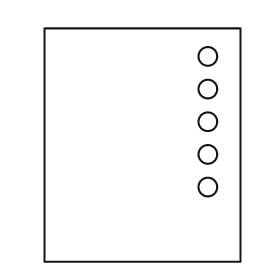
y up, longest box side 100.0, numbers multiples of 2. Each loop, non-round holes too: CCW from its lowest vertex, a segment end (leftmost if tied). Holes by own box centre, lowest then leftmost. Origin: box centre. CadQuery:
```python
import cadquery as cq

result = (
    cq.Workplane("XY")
    .moveTo(-42.0, -50.0)
    .lineTo(42.0, -50.0)
    .lineTo(42.0, 50.0)
    .lineTo(-42.0, 50.0)
    .close()
    .moveTo(28.0, -18.0)
    .circle(4.0)
    .moveTo(28.0, -4.0)
    .circle(4.0)
    .moveTo(28.0, 10.0)
    .circle(4.0)
    .moveTo(28.0, 24.0)
    .circle(4.0)
    .moveTo(28.0, 38.0)
    .circle(4.0)
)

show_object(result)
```